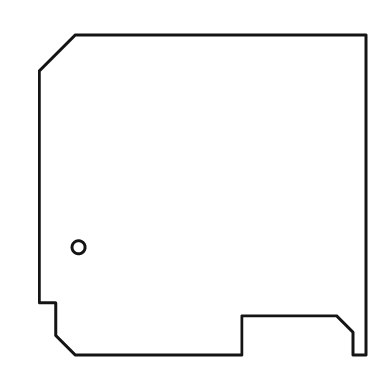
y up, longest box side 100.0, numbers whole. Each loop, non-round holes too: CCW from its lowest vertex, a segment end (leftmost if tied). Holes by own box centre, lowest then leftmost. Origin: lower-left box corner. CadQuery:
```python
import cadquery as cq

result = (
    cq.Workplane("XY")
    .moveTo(11.0, 0.0)
    .lineTo(62.0, 0.0)
    .lineTo(62.0, 12.0)
    .lineTo(91.0, 12.0)
    .lineTo(96.0, 7.0)
    .lineTo(96.0, 0.0)
    .lineTo(100.0, 0.0)
    .lineTo(100.0, 98.0)
    .lineTo(11.0, 98.0)
    .lineTo(0.0, 87.0)
    .lineTo(0.0, 16.0)
    .lineTo(5.0, 16.0)
    .lineTo(5.0, 6.0)
    .close()
    .moveTo(12.0, 33.0)
    .circle(2.0)
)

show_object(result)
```